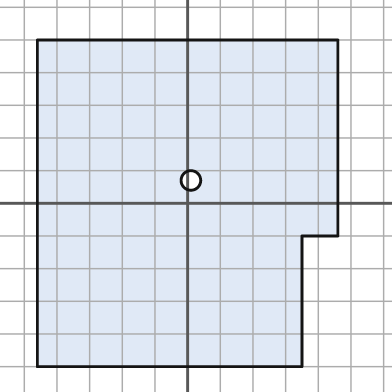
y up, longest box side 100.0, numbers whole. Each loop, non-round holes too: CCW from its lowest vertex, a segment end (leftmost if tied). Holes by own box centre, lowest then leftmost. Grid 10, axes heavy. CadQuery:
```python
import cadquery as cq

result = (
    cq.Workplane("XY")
    .moveTo(-46.0, -50.0)
    .lineTo(35.0, -50.0)
    .lineTo(35.0, -10.0)
    .lineTo(46.0, -10.0)
    .lineTo(46.0, 50.0)
    .lineTo(-46.0, 50.0)
    .close()
    .moveTo(1.0, 7.0)
    .circle(3.0)
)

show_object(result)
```